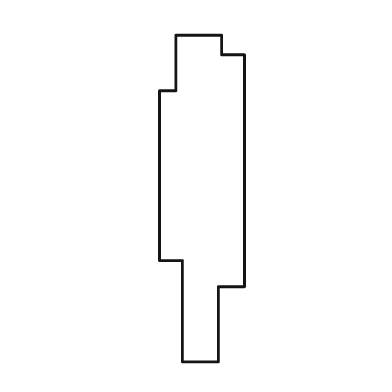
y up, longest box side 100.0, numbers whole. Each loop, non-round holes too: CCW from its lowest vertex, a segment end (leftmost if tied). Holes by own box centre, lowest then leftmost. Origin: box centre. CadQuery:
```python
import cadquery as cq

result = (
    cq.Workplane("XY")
    .moveTo(-6.0, -50.0)
    .lineTo(5.0, -50.0)
    .lineTo(5.0, -27.0)
    .lineTo(13.0, -27.0)
    .lineTo(13.0, 44.0)
    .lineTo(6.0, 44.0)
    .lineTo(6.0, 50.0)
    .lineTo(-8.0, 50.0)
    .lineTo(-8.0, 33.0)
    .lineTo(-13.0, 33.0)
    .lineTo(-13.0, -19.0)
    .lineTo(-6.0, -19.0)
    .close()
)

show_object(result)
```